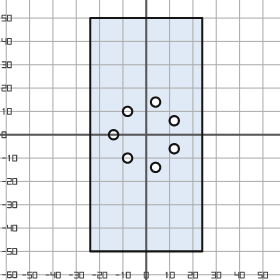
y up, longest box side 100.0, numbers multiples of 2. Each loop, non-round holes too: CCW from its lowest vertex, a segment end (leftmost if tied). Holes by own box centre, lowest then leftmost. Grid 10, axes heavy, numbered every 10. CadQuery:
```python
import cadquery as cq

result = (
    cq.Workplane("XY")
    .moveTo(-24.0, -50.0)
    .lineTo(24.0, -50.0)
    .lineTo(24.0, 50.0)
    .lineTo(-24.0, 50.0)
    .close()
    .moveTo(4.0, -14.0)
    .circle(2.0)
    .moveTo(-8.0, -10.0)
    .circle(2.0)
    .moveTo(12.0, -6.0)
    .circle(2.0)
    .moveTo(-14.0, 0.0)
    .circle(2.0)
    .moveTo(12.0, 6.0)
    .circle(2.0)
    .moveTo(-8.0, 10.0)
    .circle(2.0)
    .moveTo(4.0, 14.0)
    .circle(2.0)
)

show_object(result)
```